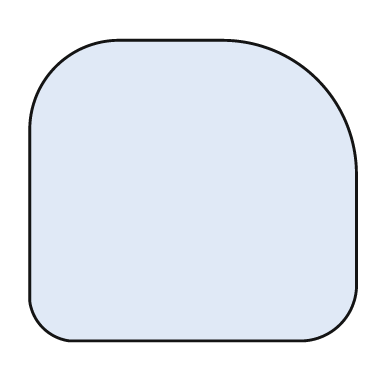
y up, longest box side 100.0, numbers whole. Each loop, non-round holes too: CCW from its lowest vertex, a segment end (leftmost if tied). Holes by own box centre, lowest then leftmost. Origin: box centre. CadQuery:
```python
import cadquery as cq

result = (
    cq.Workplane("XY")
    .moveTo(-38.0, -46.0)
    .lineTo(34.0, -46.0)
    .threePointArc((45.0, -41.0), (50.0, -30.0))
    .lineTo(50.0, 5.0)
    .threePointArc((38.0, 34.0), (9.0, 46.0))
    .lineTo(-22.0, 46.0)
    .threePointArc((-42.0, 38.0), (-50.0, 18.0))
    .lineTo(-50.0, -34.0)
    .threePointArc((-46.0, -42.0), (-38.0, -46.0))
    .close()
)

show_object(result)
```